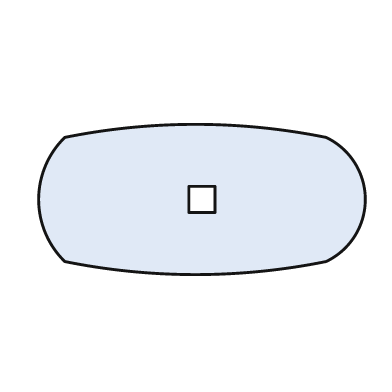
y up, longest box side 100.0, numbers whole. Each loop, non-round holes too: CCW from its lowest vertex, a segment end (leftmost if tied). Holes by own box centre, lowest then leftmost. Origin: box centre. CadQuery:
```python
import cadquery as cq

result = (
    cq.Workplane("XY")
    .moveTo(-42.0, -19.0)
    .threePointArc((-2.0, -23.0), (38.0, -19.0))
    .threePointArc((50.0, 0.0), (38.0, 19.0))
    .threePointArc((-2.0, 23.0), (-42.0, 19.0))
    .threePointArc((-50.0, 0.0), (-42.0, -19.0))
    .close()
    .moveTo(-4.0, -4.0)
    .lineTo(4.0, -4.0)
    .lineTo(4.0, 4.0)
    .lineTo(-4.0, 4.0)
    .close()
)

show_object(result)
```